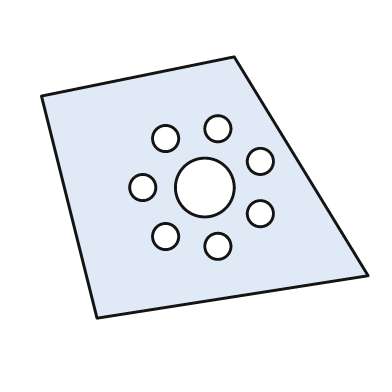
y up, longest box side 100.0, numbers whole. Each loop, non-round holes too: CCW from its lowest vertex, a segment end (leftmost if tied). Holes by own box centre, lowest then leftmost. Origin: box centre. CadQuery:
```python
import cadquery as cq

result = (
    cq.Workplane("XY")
    .moveTo(-33.0, -40.0)
    .lineTo(50.0, -27.0)
    .lineTo(9.0, 40.0)
    .lineTo(-50.0, 28.0)
    .close()
    .moveTo(4.0, -18.0)
    .circle(4.0)
    .moveTo(-12.0, -15.0)
    .circle(4.0)
    .moveTo(17.0, -8.0)
    .circle(4.0)
    .moveTo(-19.0, 0.0)
    .circle(4.0)
    .moveTo(0.0, 0.0)
    .circle(9.0)
    .moveTo(17.0, 8.0)
    .circle(4.0)
    .moveTo(-12.0, 15.0)
    .circle(4.0)
    .moveTo(4.0, 18.0)
    .circle(4.0)
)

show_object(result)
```